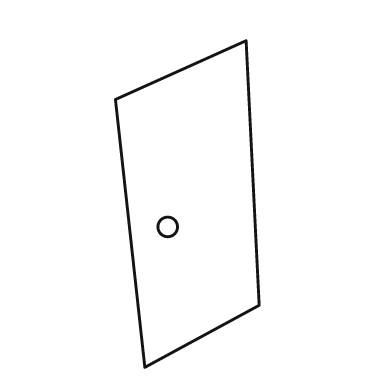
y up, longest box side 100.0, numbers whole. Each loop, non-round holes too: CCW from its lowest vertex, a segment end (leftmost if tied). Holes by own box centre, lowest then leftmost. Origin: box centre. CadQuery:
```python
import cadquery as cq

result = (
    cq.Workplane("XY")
    .moveTo(-13.0, -50.0)
    .lineTo(22.0, -31.0)
    .lineTo(18.0, 50.0)
    .lineTo(-22.0, 32.0)
    .close()
    .moveTo(-6.0, -7.0)
    .circle(3.0)
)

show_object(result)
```